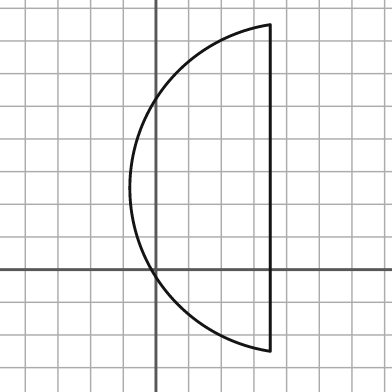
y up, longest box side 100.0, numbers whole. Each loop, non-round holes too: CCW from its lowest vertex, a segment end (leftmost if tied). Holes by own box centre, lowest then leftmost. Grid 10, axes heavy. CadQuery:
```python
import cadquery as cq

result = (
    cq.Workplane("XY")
    .moveTo(35.0, -25.0)
    .lineTo(35.0, 75.0)
    .threePointArc((-8.0, 25.0), (35.0, -25.0))
    .close()
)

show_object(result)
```